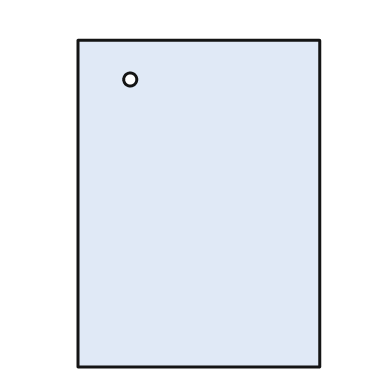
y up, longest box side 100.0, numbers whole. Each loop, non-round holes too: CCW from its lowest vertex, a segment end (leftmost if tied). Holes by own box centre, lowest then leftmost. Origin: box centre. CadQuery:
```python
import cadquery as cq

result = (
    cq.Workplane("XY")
    .moveTo(-37.0, -50.0)
    .lineTo(37.0, -50.0)
    .lineTo(37.0, 50.0)
    .lineTo(-37.0, 50.0)
    .close()
    .moveTo(-21.0, 38.0)
    .circle(2.0)
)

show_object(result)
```